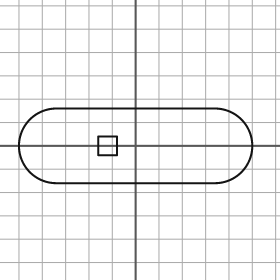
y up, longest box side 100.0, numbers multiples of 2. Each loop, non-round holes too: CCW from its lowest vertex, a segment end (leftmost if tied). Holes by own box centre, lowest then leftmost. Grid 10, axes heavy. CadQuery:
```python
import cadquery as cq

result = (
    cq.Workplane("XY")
    .moveTo(-34.0, -16.0)
    .lineTo(34.0, -16.0)
    .threePointArc((50.0, 0.0), (34.0, 16.0))
    .lineTo(-34.0, 16.0)
    .threePointArc((-50.0, 0.0), (-34.0, -16.0))
    .close()
    .moveTo(-16.0, -4.0)
    .lineTo(-8.0, -4.0)
    .lineTo(-8.0, 4.0)
    .lineTo(-16.0, 4.0)
    .close()
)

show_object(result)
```